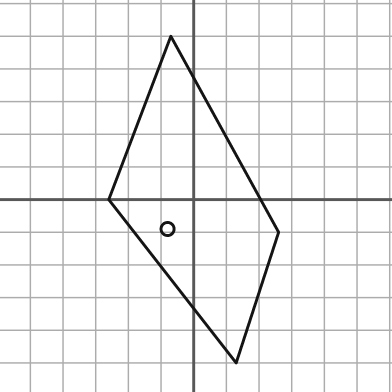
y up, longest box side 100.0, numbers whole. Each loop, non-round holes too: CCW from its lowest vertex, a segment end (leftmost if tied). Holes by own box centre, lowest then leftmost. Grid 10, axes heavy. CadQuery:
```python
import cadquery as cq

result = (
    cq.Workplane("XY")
    .moveTo(13.0, -50.0)
    .lineTo(26.0, -10.0)
    .lineTo(-7.0, 50.0)
    .lineTo(-26.0, 0.0)
    .close()
    .moveTo(-8.0, -9.0)
    .circle(2.0)
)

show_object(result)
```